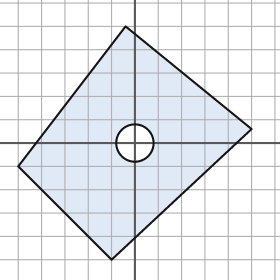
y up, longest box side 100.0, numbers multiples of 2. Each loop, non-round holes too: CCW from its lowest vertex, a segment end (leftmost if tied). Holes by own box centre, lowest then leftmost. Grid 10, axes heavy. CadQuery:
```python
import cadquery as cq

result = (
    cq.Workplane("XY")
    .moveTo(-10.0, -50.0)
    .lineTo(50.0, 6.0)
    .lineTo(-4.0, 50.0)
    .lineTo(-50.0, -10.0)
    .close()
    .moveTo(0.0, 0.0)
    .circle(8.0)
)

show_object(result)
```